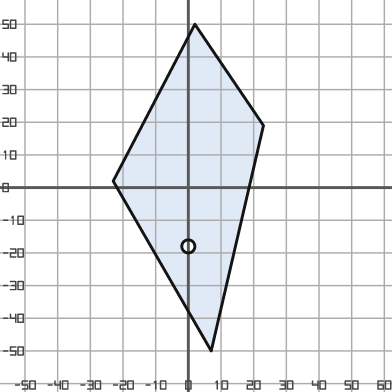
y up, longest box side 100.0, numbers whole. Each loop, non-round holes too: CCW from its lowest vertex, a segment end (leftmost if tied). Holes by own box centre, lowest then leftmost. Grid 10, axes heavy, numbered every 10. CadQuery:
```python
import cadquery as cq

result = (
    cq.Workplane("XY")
    .moveTo(7.0, -50.0)
    .lineTo(23.0, 19.0)
    .lineTo(2.0, 50.0)
    .lineTo(-23.0, 2.0)
    .close()
    .moveTo(0.0, -18.0)
    .circle(2.0)
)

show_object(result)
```